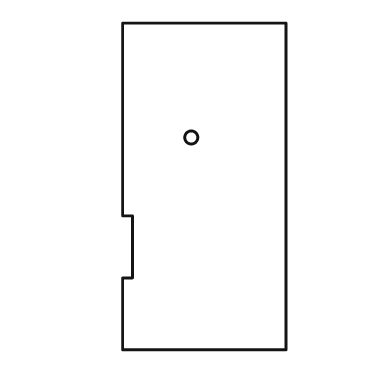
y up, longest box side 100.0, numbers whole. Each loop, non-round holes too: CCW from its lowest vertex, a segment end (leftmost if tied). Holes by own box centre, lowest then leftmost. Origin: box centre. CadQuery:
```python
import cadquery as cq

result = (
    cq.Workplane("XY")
    .moveTo(-25.0, -50.0)
    .lineTo(25.0, -50.0)
    .lineTo(25.0, 50.0)
    .lineTo(-25.0, 50.0)
    .lineTo(-25.0, -9.0)
    .lineTo(-22.0, -9.0)
    .lineTo(-22.0, -28.0)
    .lineTo(-25.0, -28.0)
    .close()
    .moveTo(-4.0, 15.0)
    .circle(2.0)
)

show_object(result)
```